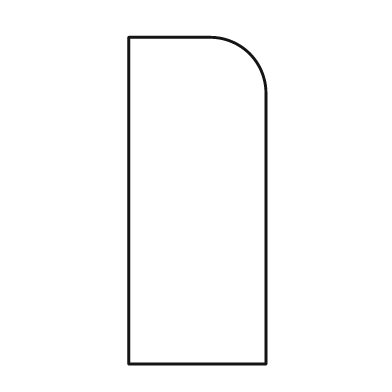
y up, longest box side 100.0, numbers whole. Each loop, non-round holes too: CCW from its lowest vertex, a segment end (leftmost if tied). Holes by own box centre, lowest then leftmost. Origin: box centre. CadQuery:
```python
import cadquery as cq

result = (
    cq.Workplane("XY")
    .moveTo(-21.0, -50.0)
    .lineTo(21.0, -50.0)
    .lineTo(21.0, 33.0)
    .threePointArc((16.0, 45.0), (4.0, 50.0))
    .lineTo(-21.0, 50.0)
    .close()
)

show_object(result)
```